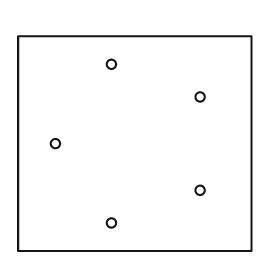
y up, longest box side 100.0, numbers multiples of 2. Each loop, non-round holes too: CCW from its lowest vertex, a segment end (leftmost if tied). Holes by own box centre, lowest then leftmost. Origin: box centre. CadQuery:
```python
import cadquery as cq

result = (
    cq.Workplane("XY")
    .moveTo(-50.0, -46.0)
    .lineTo(50.0, -46.0)
    .lineTo(50.0, 46.0)
    .lineTo(-50.0, 46.0)
    .close()
    .moveTo(-10.0, -34.0)
    .circle(2.0)
    .moveTo(28.0, -20.0)
    .circle(2.0)
    .moveTo(-34.0, 0.0)
    .circle(2.0)
    .moveTo(28.0, 20.0)
    .circle(2.0)
    .moveTo(-10.0, 34.0)
    .circle(2.0)
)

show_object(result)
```